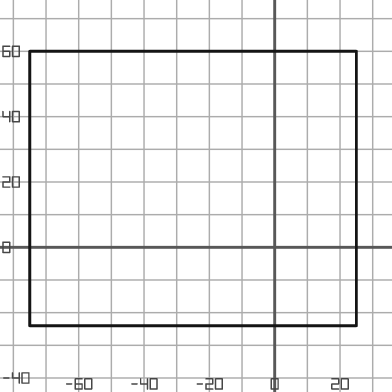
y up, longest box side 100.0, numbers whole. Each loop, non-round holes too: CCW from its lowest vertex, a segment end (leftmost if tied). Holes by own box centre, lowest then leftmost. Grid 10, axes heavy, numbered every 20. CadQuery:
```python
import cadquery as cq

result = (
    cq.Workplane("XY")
    .moveTo(-75.0, -24.0)
    .lineTo(25.0, -24.0)
    .lineTo(25.0, 60.0)
    .lineTo(-75.0, 60.0)
    .close()
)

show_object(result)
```